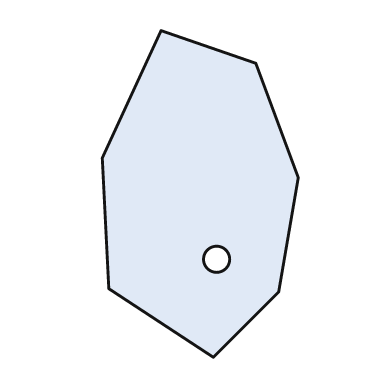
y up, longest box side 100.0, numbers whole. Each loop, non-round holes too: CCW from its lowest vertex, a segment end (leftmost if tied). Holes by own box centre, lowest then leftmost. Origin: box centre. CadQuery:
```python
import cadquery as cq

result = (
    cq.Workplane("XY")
    .moveTo(4.0, -50.0)
    .lineTo(24.0, -30.0)
    .lineTo(30.0, 5.0)
    .lineTo(17.0, 40.0)
    .lineTo(-12.0, 50.0)
    .lineTo(-30.0, 11.0)
    .lineTo(-28.0, -29.0)
    .close()
    .moveTo(5.0, -20.0)
    .circle(4.0)
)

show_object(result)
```